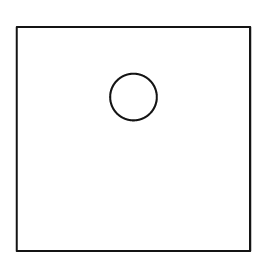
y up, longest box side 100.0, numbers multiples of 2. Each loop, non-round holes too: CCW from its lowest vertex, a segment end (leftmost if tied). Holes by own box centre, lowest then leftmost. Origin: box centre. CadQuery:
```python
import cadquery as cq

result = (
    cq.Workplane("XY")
    .moveTo(-50.0, -48.0)
    .lineTo(50.0, -48.0)
    .lineTo(50.0, 48.0)
    .lineTo(-50.0, 48.0)
    .close()
    .moveTo(0.0, 18.0)
    .circle(10.0)
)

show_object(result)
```